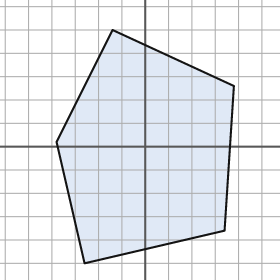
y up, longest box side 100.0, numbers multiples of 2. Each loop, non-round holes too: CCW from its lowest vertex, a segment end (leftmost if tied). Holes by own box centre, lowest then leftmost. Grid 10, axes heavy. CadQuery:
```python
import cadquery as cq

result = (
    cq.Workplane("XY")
    .moveTo(-26.0, -50.0)
    .lineTo(34.0, -36.0)
    .lineTo(38.0, 26.0)
    .lineTo(-14.0, 50.0)
    .lineTo(-38.0, 2.0)
    .close()
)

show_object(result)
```